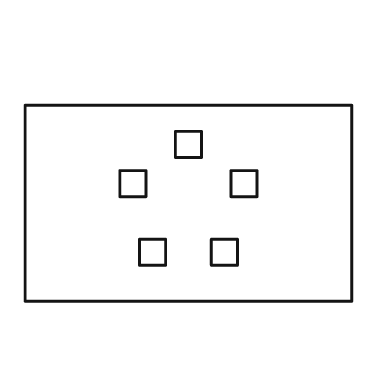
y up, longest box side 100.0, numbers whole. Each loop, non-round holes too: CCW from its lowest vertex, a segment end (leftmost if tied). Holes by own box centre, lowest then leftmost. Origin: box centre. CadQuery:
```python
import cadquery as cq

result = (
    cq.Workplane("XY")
    .moveTo(-50.0, -30.0)
    .lineTo(50.0, -30.0)
    .lineTo(50.0, 30.0)
    .lineTo(-50.0, 30.0)
    .close()
    .moveTo(-15.0, -19.0)
    .lineTo(-7.0, -19.0)
    .lineTo(-7.0, -11.0)
    .lineTo(-15.0, -11.0)
    .close()
    .moveTo(7.0, -19.0)
    .lineTo(15.0, -19.0)
    .lineTo(15.0, -11.0)
    .lineTo(7.0, -11.0)
    .close()
    .moveTo(-21.0, 2.0)
    .lineTo(-13.0, 2.0)
    .lineTo(-13.0, 10.0)
    .lineTo(-21.0, 10.0)
    .close()
    .moveTo(13.0, 2.0)
    .lineTo(21.0, 2.0)
    .lineTo(21.0, 10.0)
    .lineTo(13.0, 10.0)
    .close()
    .moveTo(-4.0, 14.0)
    .lineTo(4.0, 14.0)
    .lineTo(4.0, 22.0)
    .lineTo(-4.0, 22.0)
    .close()
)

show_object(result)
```